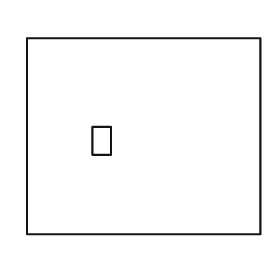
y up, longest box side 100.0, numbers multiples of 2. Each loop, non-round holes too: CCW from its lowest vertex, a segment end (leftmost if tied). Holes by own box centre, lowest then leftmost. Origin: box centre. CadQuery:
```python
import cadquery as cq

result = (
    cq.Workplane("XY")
    .moveTo(-50.0, -42.0)
    .lineTo(50.0, -42.0)
    .lineTo(50.0, 42.0)
    .lineTo(-50.0, 42.0)
    .close()
    .moveTo(-22.0, -8.0)
    .lineTo(-14.0, -8.0)
    .lineTo(-14.0, 4.0)
    .lineTo(-22.0, 4.0)
    .close()
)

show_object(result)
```